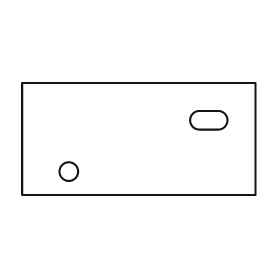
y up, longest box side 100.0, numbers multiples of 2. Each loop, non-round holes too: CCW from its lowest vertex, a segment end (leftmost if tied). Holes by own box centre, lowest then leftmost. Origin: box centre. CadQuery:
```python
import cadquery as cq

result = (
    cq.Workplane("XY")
    .moveTo(-50.0, -24.0)
    .lineTo(50.0, -24.0)
    .lineTo(50.0, 24.0)
    .lineTo(-50.0, 24.0)
    .close()
    .moveTo(-30.0, -14.0)
    .circle(4.0)
    .moveTo(26.0, 4.0)
    .lineTo(34.0, 4.0)
    .threePointArc((38.0, 8.0), (34.0, 12.0))
    .lineTo(26.0, 12.0)
    .threePointArc((22.0, 8.0), (26.0, 4.0))
    .close()
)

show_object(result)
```